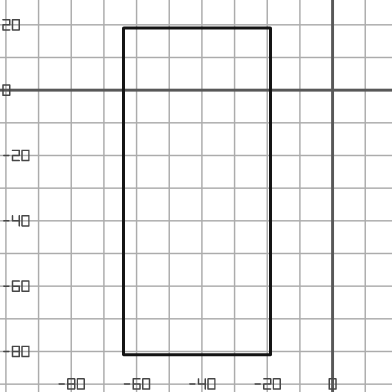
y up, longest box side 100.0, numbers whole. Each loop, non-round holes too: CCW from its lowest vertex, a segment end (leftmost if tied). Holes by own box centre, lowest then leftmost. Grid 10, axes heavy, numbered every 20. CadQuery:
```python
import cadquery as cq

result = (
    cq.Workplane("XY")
    .moveTo(-64.0, -81.0)
    .lineTo(-19.0, -81.0)
    .lineTo(-19.0, 19.0)
    .lineTo(-64.0, 19.0)
    .close()
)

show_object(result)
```